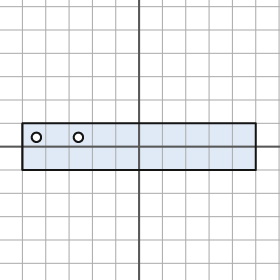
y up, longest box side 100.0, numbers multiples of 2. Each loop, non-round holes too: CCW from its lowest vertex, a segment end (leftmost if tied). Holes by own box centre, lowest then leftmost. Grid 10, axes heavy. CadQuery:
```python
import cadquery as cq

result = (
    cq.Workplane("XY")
    .moveTo(-50.0, -10.0)
    .lineTo(50.0, -10.0)
    .lineTo(50.0, 10.0)
    .lineTo(-50.0, 10.0)
    .close()
    .moveTo(-44.0, 4.0)
    .circle(2.0)
    .moveTo(-26.0, 4.0)
    .circle(2.0)
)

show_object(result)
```